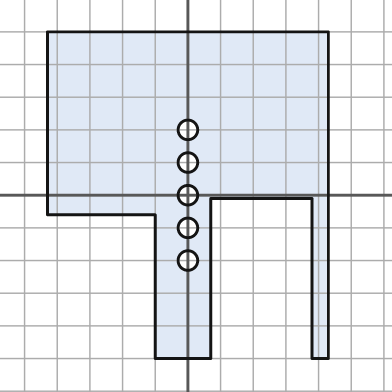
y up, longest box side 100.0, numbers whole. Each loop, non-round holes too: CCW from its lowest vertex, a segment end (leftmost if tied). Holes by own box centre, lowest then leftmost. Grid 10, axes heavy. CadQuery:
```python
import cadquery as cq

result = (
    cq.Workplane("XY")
    .moveTo(-10.0, -50.0)
    .lineTo(7.0, -50.0)
    .lineTo(7.0, -1.0)
    .lineTo(38.0, -1.0)
    .lineTo(38.0, -50.0)
    .lineTo(43.0, -50.0)
    .lineTo(43.0, 50.0)
    .lineTo(-43.0, 50.0)
    .lineTo(-43.0, -6.0)
    .lineTo(-10.0, -6.0)
    .close()
    .moveTo(0.0, -20.0)
    .circle(3.0)
    .moveTo(0.0, -10.0)
    .circle(3.0)
    .moveTo(0.0, 0.0)
    .circle(3.0)
    .moveTo(0.0, 10.0)
    .circle(3.0)
    .moveTo(0.0, 20.0)
    .circle(3.0)
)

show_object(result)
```